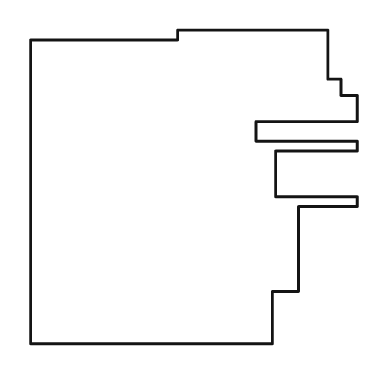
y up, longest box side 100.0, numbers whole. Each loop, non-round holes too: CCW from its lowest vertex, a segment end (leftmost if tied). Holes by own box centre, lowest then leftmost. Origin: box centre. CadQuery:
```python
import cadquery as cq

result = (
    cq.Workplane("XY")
    .moveTo(-50.0, -48.0)
    .lineTo(24.0, -48.0)
    .lineTo(24.0, -32.0)
    .lineTo(32.0, -32.0)
    .lineTo(32.0, -6.0)
    .lineTo(50.0, -6.0)
    .lineTo(50.0, -3.0)
    .lineTo(25.0, -3.0)
    .lineTo(25.0, 11.0)
    .lineTo(50.0, 11.0)
    .lineTo(50.0, 14.0)
    .lineTo(19.0, 14.0)
    .lineTo(19.0, 20.0)
    .lineTo(50.0, 20.0)
    .lineTo(50.0, 28.0)
    .lineTo(45.0, 28.0)
    .lineTo(45.0, 33.0)
    .lineTo(41.0, 33.0)
    .lineTo(41.0, 48.0)
    .lineTo(-5.0, 48.0)
    .lineTo(-5.0, 45.0)
    .lineTo(-50.0, 45.0)
    .close()
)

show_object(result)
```